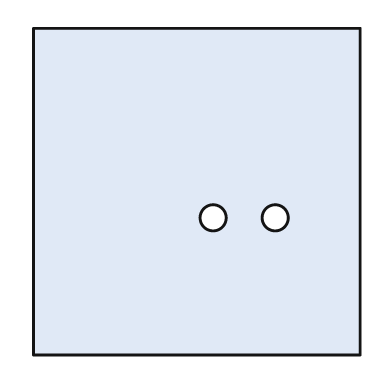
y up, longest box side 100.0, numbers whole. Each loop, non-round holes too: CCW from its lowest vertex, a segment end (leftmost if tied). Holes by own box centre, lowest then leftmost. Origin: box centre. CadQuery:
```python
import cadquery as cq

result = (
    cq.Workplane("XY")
    .moveTo(-50.0, -50.0)
    .lineTo(50.0, -50.0)
    .lineTo(50.0, 50.0)
    .lineTo(-50.0, 50.0)
    .close()
    .moveTo(5.0, -8.0)
    .circle(4.0)
    .moveTo(24.0, -8.0)
    .circle(4.0)
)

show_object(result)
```